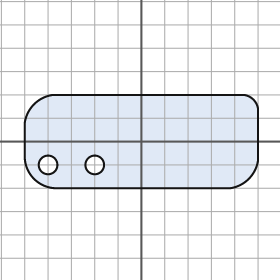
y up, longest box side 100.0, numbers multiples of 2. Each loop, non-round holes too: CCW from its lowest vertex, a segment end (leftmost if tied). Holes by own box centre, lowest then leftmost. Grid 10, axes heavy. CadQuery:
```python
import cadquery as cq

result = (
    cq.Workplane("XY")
    .moveTo(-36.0, -20.0)
    .lineTo(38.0, -20.0)
    .threePointArc((46.0, -16.0), (50.0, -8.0))
    .lineTo(50.0, 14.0)
    .threePointArc((48.0, 18.0), (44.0, 20.0))
    .lineTo(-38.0, 20.0)
    .threePointArc((-46.0, 16.0), (-50.0, 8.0))
    .lineTo(-50.0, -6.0)
    .threePointArc((-46.0, -16.0), (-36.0, -20.0))
    .close()
    .moveTo(-40.0, -10.0)
    .circle(4.0)
    .moveTo(-20.0, -10.0)
    .circle(4.0)
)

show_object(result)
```